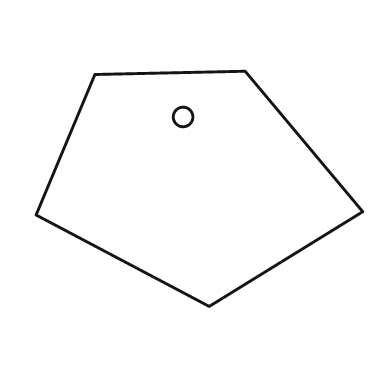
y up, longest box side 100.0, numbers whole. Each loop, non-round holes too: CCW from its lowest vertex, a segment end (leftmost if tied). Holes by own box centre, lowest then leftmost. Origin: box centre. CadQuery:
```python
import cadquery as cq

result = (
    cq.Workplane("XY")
    .moveTo(3.0, -36.0)
    .lineTo(50.0, -7.0)
    .lineTo(14.0, 36.0)
    .lineTo(-32.0, 35.0)
    .lineTo(-50.0, -8.0)
    .close()
    .moveTo(-5.0, 22.0)
    .circle(3.0)
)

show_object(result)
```